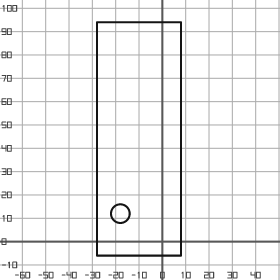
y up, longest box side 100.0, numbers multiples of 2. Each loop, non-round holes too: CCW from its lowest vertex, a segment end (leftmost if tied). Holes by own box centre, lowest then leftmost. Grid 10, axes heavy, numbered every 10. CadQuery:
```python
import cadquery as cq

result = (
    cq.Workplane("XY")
    .moveTo(-28.0, -6.0)
    .lineTo(8.0, -6.0)
    .lineTo(8.0, 94.0)
    .lineTo(-28.0, 94.0)
    .close()
    .moveTo(-18.0, 12.0)
    .circle(4.0)
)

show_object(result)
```